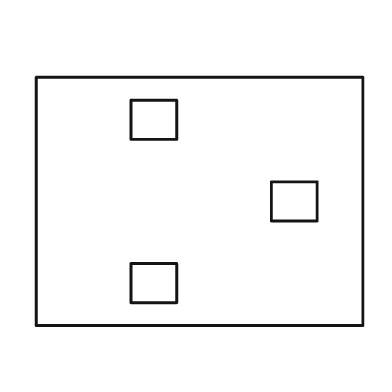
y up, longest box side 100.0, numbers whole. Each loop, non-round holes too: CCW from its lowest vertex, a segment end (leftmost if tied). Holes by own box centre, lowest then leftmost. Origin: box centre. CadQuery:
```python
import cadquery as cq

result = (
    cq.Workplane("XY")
    .moveTo(-50.0, -38.0)
    .lineTo(50.0, -38.0)
    .lineTo(50.0, 38.0)
    .lineTo(-50.0, 38.0)
    .close()
    .moveTo(-21.0, -31.0)
    .lineTo(-7.0, -31.0)
    .lineTo(-7.0, -19.0)
    .lineTo(-21.0, -19.0)
    .close()
    .moveTo(22.0, -6.0)
    .lineTo(36.0, -6.0)
    .lineTo(36.0, 6.0)
    .lineTo(22.0, 6.0)
    .close()
    .moveTo(-21.0, 19.0)
    .lineTo(-7.0, 19.0)
    .lineTo(-7.0, 31.0)
    .lineTo(-21.0, 31.0)
    .close()
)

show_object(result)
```